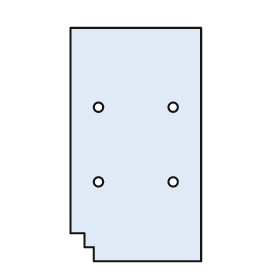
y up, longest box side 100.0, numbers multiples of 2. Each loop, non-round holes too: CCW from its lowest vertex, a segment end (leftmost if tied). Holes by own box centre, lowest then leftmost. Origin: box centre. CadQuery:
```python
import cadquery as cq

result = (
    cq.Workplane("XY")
    .moveTo(-18.0, -50.0)
    .lineTo(28.0, -50.0)
    .lineTo(28.0, 50.0)
    .lineTo(-28.0, 50.0)
    .lineTo(-28.0, -38.0)
    .lineTo(-22.0, -38.0)
    .lineTo(-22.0, -44.0)
    .lineTo(-18.0, -44.0)
    .close()
    .moveTo(-16.0, -16.0)
    .circle(2.0)
    .moveTo(16.0, -16.0)
    .circle(2.0)
    .moveTo(-16.0, 16.0)
    .circle(2.0)
    .moveTo(16.0, 16.0)
    .circle(2.0)
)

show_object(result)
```